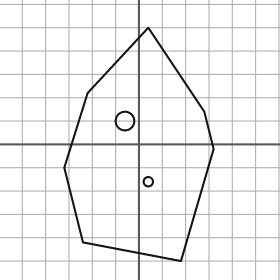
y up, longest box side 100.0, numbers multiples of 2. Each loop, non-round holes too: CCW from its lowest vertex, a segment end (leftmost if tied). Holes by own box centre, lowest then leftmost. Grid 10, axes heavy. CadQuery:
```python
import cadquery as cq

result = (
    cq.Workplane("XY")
    .moveTo(18.0, -50.0)
    .lineTo(32.0, -2.0)
    .lineTo(28.0, 14.0)
    .lineTo(4.0, 50.0)
    .lineTo(-22.0, 22.0)
    .lineTo(-32.0, -10.0)
    .lineTo(-24.0, -42.0)
    .close()
    .moveTo(4.0, -16.0)
    .circle(2.0)
    .moveTo(-6.0, 10.0)
    .circle(4.0)
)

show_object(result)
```